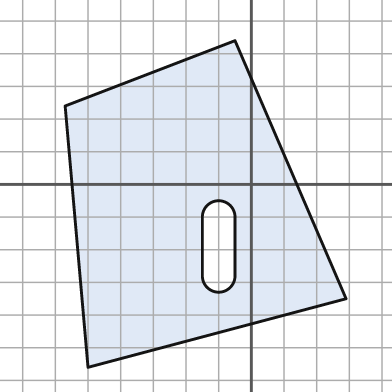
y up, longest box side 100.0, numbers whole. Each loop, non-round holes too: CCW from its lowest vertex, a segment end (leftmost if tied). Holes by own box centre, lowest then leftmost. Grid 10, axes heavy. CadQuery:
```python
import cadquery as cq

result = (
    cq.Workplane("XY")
    .moveTo(-50.0, -56.0)
    .lineTo(29.0, -35.0)
    .lineTo(-5.0, 44.0)
    .lineTo(-57.0, 24.0)
    .close()
    .moveTo(-15.0, -28.0)
    .threePointArc((-10.0, -33.0), (-5.0, -28.0))
    .lineTo(-5.0, -10.0)
    .threePointArc((-10.0, -5.0), (-15.0, -10.0))
    .close()
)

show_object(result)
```